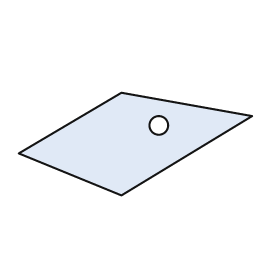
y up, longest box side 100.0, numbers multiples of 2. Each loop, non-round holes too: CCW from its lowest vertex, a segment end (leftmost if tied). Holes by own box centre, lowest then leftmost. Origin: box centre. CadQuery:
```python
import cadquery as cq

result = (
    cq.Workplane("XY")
    .moveTo(-6.0, -22.0)
    .lineTo(50.0, 12.0)
    .lineTo(-6.0, 22.0)
    .lineTo(-50.0, -4.0)
    .close()
    .moveTo(10.0, 8.0)
    .circle(4.0)
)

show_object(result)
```